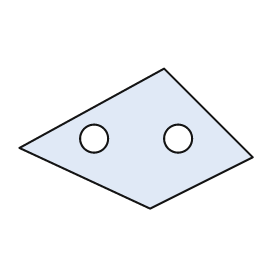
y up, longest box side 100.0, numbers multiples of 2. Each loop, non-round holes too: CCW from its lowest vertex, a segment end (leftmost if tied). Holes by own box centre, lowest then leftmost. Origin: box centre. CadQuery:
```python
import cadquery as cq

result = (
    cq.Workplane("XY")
    .moveTo(6.0, -30.0)
    .lineTo(50.0, -8.0)
    .lineTo(12.0, 30.0)
    .lineTo(-50.0, -4.0)
    .close()
    .moveTo(-18.0, 0.0)
    .circle(6.0)
    .moveTo(18.0, 0.0)
    .circle(6.0)
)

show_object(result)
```